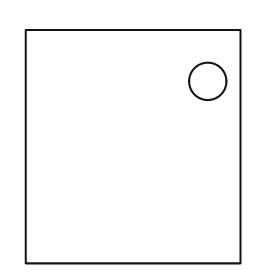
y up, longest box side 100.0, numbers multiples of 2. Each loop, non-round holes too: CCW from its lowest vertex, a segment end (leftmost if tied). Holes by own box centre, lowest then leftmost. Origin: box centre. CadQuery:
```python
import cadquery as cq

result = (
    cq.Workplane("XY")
    .moveTo(-46.0, -50.0)
    .lineTo(46.0, -50.0)
    .lineTo(46.0, 50.0)
    .lineTo(-46.0, 50.0)
    .close()
    .moveTo(32.0, 28.0)
    .circle(8.0)
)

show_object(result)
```